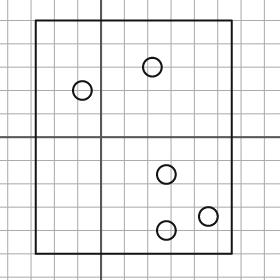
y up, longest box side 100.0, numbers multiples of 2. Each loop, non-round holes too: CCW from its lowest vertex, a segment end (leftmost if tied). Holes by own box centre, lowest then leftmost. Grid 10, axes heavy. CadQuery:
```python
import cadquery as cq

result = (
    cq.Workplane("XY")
    .moveTo(-28.0, -50.0)
    .lineTo(56.0, -50.0)
    .lineTo(56.0, 50.0)
    .lineTo(-28.0, 50.0)
    .close()
    .moveTo(28.0, -40.0)
    .circle(4.0)
    .moveTo(46.0, -34.0)
    .circle(4.0)
    .moveTo(28.0, -16.0)
    .circle(4.0)
    .moveTo(-8.0, 20.0)
    .circle(4.0)
    .moveTo(22.0, 30.0)
    .circle(4.0)
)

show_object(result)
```